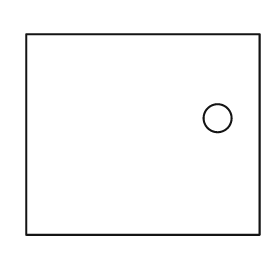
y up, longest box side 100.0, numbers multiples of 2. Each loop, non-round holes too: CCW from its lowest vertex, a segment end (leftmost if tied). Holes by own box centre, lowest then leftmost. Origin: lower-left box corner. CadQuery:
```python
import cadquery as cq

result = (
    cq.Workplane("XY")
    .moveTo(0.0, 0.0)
    .lineTo(100.0, 0.0)
    .lineTo(100.0, 86.0)
    .lineTo(0.0, 86.0)
    .close()
    .moveTo(82.0, 50.0)
    .circle(6.0)
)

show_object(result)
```